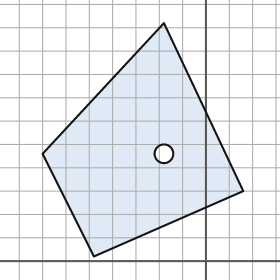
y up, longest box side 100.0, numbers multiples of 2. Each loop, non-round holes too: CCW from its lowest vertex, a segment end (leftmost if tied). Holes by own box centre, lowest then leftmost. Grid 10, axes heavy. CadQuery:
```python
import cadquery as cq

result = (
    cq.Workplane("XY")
    .moveTo(-48.0, 2.0)
    .lineTo(16.0, 30.0)
    .lineTo(-18.0, 102.0)
    .lineTo(-70.0, 46.0)
    .close()
    .moveTo(-18.0, 46.0)
    .circle(4.0)
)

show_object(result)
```